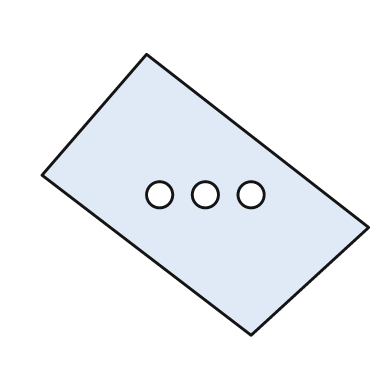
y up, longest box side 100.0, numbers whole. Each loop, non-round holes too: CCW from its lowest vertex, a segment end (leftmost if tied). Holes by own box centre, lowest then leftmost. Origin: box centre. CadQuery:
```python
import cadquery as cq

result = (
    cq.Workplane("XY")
    .moveTo(14.0, -43.0)
    .lineTo(50.0, -10.0)
    .lineTo(-18.0, 43.0)
    .lineTo(-50.0, 6.0)
    .close()
    .moveTo(-14.0, 0.0)
    .circle(4.0)
    .moveTo(0.0, 0.0)
    .circle(4.0)
    .moveTo(14.0, 0.0)
    .circle(4.0)
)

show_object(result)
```